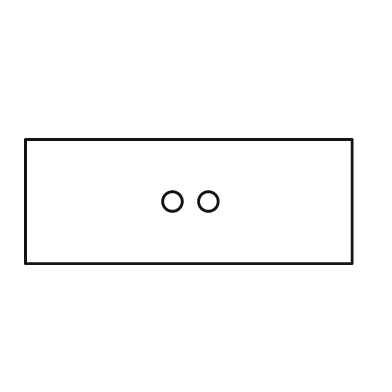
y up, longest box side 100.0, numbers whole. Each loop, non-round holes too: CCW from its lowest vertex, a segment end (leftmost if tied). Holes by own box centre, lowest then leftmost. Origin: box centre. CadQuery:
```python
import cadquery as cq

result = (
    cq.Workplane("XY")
    .moveTo(-50.0, -19.0)
    .lineTo(50.0, -19.0)
    .lineTo(50.0, 19.0)
    .lineTo(-50.0, 19.0)
    .close()
    .moveTo(-5.0, 0.0)
    .circle(3.0)
    .moveTo(6.0, 0.0)
    .circle(3.0)
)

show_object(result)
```